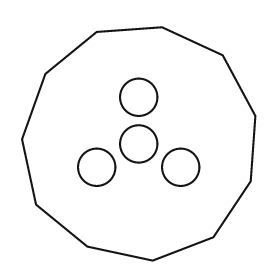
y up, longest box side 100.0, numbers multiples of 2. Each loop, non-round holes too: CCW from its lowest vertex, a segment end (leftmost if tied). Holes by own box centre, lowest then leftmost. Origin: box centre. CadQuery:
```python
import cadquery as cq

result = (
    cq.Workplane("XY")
    .moveTo(6.0, -50.0)
    .lineTo(32.0, -40.0)
    .lineTo(48.0, -16.0)
    .lineTo(50.0, 12.0)
    .lineTo(36.0, 38.0)
    .lineTo(10.0, 50.0)
    .lineTo(-18.0, 48.0)
    .lineTo(-40.0, 30.0)
    .lineTo(-50.0, 2.0)
    .lineTo(-44.0, -26.0)
    .lineTo(-22.0, -44.0)
    .close()
    .moveTo(-18.0, -10.0)
    .circle(8.0)
    .moveTo(18.0, -10.0)
    .circle(8.0)
    .moveTo(0.0, 0.0)
    .circle(8.0)
    .moveTo(0.0, 20.0)
    .circle(8.0)
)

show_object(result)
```